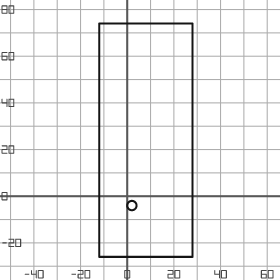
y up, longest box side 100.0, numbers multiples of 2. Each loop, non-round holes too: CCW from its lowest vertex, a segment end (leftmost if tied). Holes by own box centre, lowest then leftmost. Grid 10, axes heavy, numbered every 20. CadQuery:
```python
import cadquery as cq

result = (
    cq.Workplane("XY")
    .moveTo(-12.0, -26.0)
    .lineTo(28.0, -26.0)
    .lineTo(28.0, 74.0)
    .lineTo(-12.0, 74.0)
    .close()
    .moveTo(2.0, -4.0)
    .circle(2.0)
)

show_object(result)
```